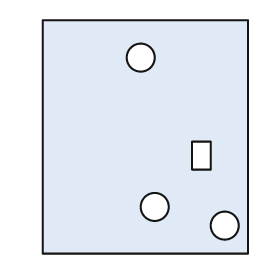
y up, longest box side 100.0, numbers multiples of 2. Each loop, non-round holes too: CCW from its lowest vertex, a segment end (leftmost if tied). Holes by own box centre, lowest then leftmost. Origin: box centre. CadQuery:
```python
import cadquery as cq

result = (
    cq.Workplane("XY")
    .moveTo(-44.0, -50.0)
    .lineTo(44.0, -50.0)
    .lineTo(44.0, 50.0)
    .lineTo(-44.0, 50.0)
    .close()
    .moveTo(34.0, -38.0)
    .circle(6.0)
    .moveTo(4.0, -30.0)
    .circle(6.0)
    .moveTo(20.0, -14.0)
    .lineTo(28.0, -14.0)
    .lineTo(28.0, -2.0)
    .lineTo(20.0, -2.0)
    .close()
    .moveTo(-2.0, 34.0)
    .circle(6.0)
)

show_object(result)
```